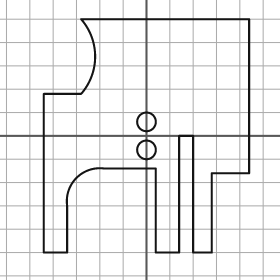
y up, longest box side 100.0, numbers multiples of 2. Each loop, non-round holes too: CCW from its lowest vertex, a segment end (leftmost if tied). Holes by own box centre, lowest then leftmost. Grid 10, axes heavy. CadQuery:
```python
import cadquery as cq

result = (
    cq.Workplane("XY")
    .moveTo(-44.0, -50.0)
    .lineTo(-34.0, -50.0)
    .lineTo(-34.0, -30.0)
    .threePointArc((-30.0, -18.0), (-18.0, -14.0))
    .lineTo(4.0, -14.0)
    .lineTo(4.0, -50.0)
    .lineTo(14.0, -50.0)
    .lineTo(14.0, 0.0)
    .lineTo(20.0, 0.0)
    .lineTo(20.0, -50.0)
    .lineTo(28.0, -50.0)
    .lineTo(28.0, -16.0)
    .lineTo(44.0, -16.0)
    .lineTo(44.0, 50.0)
    .lineTo(-28.0, 50.0)
    .threePointArc((-22.0, 34.0), (-28.0, 18.0))
    .lineTo(-44.0, 18.0)
    .close()
    .moveTo(0.0, -6.0)
    .circle(4.0)
    .moveTo(0.0, 6.0)
    .circle(4.0)
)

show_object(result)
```